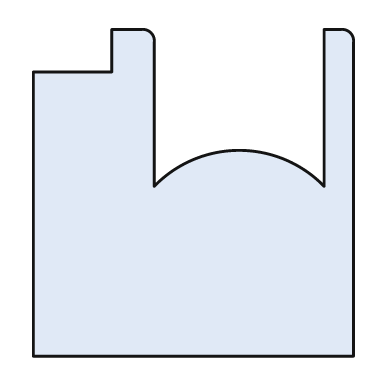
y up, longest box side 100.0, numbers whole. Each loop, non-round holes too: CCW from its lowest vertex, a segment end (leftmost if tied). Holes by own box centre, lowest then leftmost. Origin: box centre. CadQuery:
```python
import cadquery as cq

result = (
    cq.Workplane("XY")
    .moveTo(-49.0, -50.0)
    .lineTo(49.0, -50.0)
    .lineTo(49.0, 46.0)
    .threePointArc((48.0, 49.0), (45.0, 50.0))
    .lineTo(40.0, 50.0)
    .lineTo(40.0, 2.0)
    .threePointArc((14.0, 13.0), (-12.0, 2.0))
    .lineTo(-12.0, 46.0)
    .threePointArc((-13.0, 49.0), (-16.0, 50.0))
    .lineTo(-25.0, 50.0)
    .lineTo(-25.0, 37.0)
    .lineTo(-49.0, 37.0)
    .close()
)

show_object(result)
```